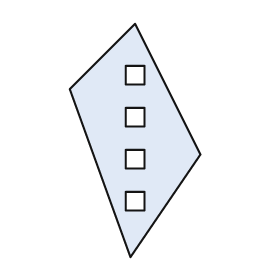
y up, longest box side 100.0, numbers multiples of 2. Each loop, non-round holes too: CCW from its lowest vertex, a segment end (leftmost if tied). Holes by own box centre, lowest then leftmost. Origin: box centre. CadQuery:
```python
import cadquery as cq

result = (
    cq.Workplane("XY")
    .moveTo(-2.0, -50.0)
    .lineTo(28.0, -6.0)
    .lineTo(0.0, 50.0)
    .lineTo(-28.0, 22.0)
    .close()
    .moveTo(-4.0, -30.0)
    .lineTo(4.0, -30.0)
    .lineTo(4.0, -22.0)
    .lineTo(-4.0, -22.0)
    .close()
    .moveTo(-4.0, -12.0)
    .lineTo(4.0, -12.0)
    .lineTo(4.0, -4.0)
    .lineTo(-4.0, -4.0)
    .close()
    .moveTo(-4.0, 6.0)
    .lineTo(4.0, 6.0)
    .lineTo(4.0, 14.0)
    .lineTo(-4.0, 14.0)
    .close()
    .moveTo(-4.0, 24.0)
    .lineTo(4.0, 24.0)
    .lineTo(4.0, 32.0)
    .lineTo(-4.0, 32.0)
    .close()
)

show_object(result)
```